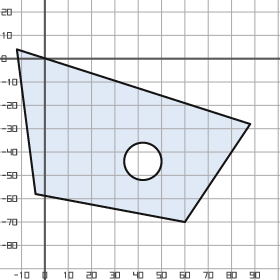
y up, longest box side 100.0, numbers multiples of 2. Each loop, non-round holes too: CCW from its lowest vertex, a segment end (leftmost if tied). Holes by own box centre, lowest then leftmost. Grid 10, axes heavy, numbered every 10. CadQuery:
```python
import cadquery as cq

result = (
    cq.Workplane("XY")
    .moveTo(60.0, -70.0)
    .lineTo(88.0, -28.0)
    .lineTo(-12.0, 4.0)
    .lineTo(-4.0, -58.0)
    .close()
    .moveTo(42.0, -44.0)
    .circle(8.0)
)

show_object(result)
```